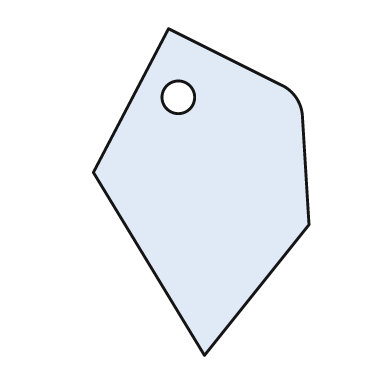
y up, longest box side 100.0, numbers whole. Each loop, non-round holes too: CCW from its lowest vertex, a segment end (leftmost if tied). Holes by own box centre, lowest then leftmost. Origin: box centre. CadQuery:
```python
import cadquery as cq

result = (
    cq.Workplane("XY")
    .moveTo(1.0, -50.0)
    .lineTo(33.0, -10.0)
    .lineTo(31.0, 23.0)
    .threePointArc((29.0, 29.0), (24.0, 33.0))
    .lineTo(-10.0, 50.0)
    .lineTo(-33.0, 6.0)
    .close()
    .moveTo(-7.0, 29.0)
    .circle(5.0)
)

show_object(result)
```